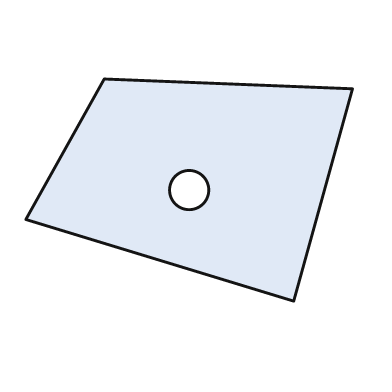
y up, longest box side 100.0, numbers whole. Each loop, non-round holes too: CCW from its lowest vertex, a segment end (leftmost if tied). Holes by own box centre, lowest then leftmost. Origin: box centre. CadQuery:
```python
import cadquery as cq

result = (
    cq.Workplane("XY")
    .moveTo(32.0, -34.0)
    .lineTo(50.0, 31.0)
    .lineTo(-26.0, 34.0)
    .lineTo(-50.0, -9.0)
    .close()
    .moveTo(0.0, 0.0)
    .circle(6.0)
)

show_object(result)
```